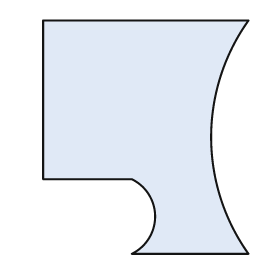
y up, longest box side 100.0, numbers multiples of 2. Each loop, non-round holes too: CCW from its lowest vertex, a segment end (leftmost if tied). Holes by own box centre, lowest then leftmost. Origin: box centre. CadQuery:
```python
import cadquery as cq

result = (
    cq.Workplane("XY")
    .moveTo(-6.0, -50.0)
    .lineTo(44.0, -50.0)
    .threePointArc((28.0, 0.0), (44.0, 50.0))
    .lineTo(-44.0, 50.0)
    .lineTo(-44.0, -18.0)
    .lineTo(-6.0, -18.0)
    .threePointArc((4.0, -34.0), (-6.0, -50.0))
    .close()
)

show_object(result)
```